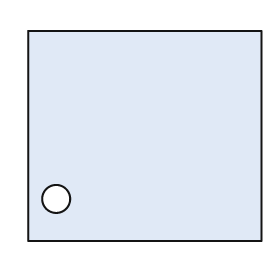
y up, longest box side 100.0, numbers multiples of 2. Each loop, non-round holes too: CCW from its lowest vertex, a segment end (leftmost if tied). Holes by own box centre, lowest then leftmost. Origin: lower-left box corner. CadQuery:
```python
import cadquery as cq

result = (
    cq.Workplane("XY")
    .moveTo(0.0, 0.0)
    .lineTo(100.0, 0.0)
    .lineTo(100.0, 90.0)
    .lineTo(0.0, 90.0)
    .close()
    .moveTo(12.0, 18.0)
    .circle(6.0)
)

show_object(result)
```